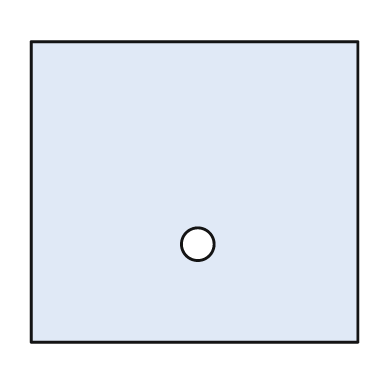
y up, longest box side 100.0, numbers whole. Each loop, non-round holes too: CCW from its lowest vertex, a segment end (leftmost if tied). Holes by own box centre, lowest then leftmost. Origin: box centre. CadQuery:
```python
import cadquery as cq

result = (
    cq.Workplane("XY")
    .moveTo(-50.0, -46.0)
    .lineTo(50.0, -46.0)
    .lineTo(50.0, 46.0)
    .lineTo(-50.0, 46.0)
    .close()
    .moveTo(1.0, -16.0)
    .circle(5.0)
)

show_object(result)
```